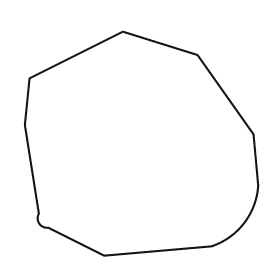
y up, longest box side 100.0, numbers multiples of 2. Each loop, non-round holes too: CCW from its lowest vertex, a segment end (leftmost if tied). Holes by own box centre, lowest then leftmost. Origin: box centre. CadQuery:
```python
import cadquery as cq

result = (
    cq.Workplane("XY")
    .moveTo(-16.0, -48.0)
    .lineTo(30.0, -44.0)
    .threePointArc((44.0, -34.0), (50.0, -18.0))
    .lineTo(48.0, 4.0)
    .lineTo(24.0, 38.0)
    .lineTo(-8.0, 48.0)
    .lineTo(-48.0, 28.0)
    .lineTo(-50.0, 8.0)
    .lineTo(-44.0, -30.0)
    .threePointArc((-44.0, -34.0), (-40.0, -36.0))
    .close()
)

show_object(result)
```